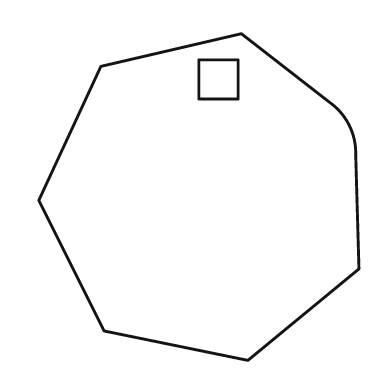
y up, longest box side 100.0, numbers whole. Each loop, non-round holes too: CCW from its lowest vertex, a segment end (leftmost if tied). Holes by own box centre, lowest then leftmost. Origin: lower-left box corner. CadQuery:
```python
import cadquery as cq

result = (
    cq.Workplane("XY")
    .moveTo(64.0, 0.0)
    .lineTo(98.0, 28.0)
    .lineTo(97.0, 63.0)
    .threePointArc((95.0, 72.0), (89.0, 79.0))
    .lineTo(62.0, 100.0)
    .lineTo(19.0, 90.0)
    .lineTo(0.0, 49.0)
    .lineTo(20.0, 9.0)
    .close()
    .moveTo(49.0, 80.0)
    .lineTo(61.0, 80.0)
    .lineTo(61.0, 92.0)
    .lineTo(49.0, 92.0)
    .close()
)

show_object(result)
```